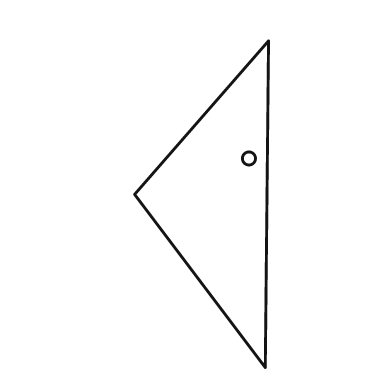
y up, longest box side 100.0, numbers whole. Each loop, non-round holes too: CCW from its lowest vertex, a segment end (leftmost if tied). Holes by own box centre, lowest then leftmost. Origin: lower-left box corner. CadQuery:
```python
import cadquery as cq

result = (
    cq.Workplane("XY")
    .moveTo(40.0, 0.0)
    .lineTo(41.0, 100.0)
    .lineTo(0.0, 53.0)
    .close()
    .moveTo(35.0, 64.0)
    .circle(2.0)
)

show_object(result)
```